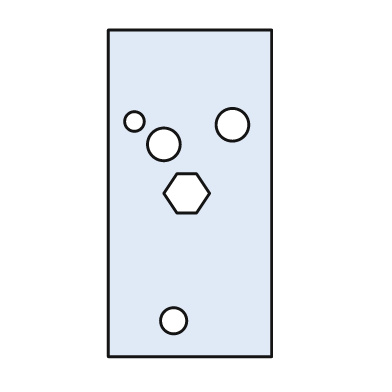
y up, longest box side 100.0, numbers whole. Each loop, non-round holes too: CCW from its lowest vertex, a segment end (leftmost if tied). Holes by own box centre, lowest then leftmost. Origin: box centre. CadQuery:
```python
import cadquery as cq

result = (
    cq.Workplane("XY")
    .moveTo(-25.0, -50.0)
    .lineTo(25.0, -50.0)
    .lineTo(25.0, 50.0)
    .lineTo(-25.0, 50.0)
    .close()
    .moveTo(-5.0, -39.0)
    .circle(4.0)
    .moveTo(-4.0, -6.0)
    .lineTo(2.0, -6.0)
    .lineTo(6.0, 0.0)
    .lineTo(2.0, 6.0)
    .lineTo(-4.0, 6.0)
    .lineTo(-8.0, 0.0)
    .close()
    .moveTo(-8.0, 15.0)
    .circle(5.0)
    .moveTo(13.0, 21.0)
    .circle(5.0)
    .moveTo(-17.0, 22.0)
    .circle(3.0)
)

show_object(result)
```